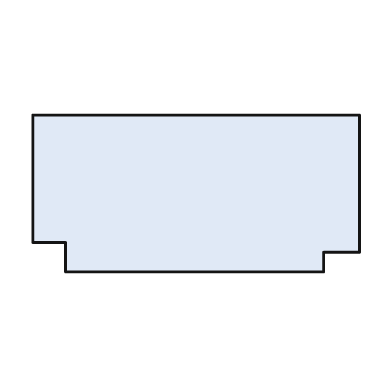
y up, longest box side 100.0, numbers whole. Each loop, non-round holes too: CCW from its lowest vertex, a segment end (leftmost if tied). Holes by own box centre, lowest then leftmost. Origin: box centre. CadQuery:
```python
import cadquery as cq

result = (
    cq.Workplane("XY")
    .moveTo(-40.0, -24.0)
    .lineTo(39.0, -24.0)
    .lineTo(39.0, -18.0)
    .lineTo(50.0, -18.0)
    .lineTo(50.0, 24.0)
    .lineTo(-50.0, 24.0)
    .lineTo(-50.0, -15.0)
    .lineTo(-40.0, -15.0)
    .close()
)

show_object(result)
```